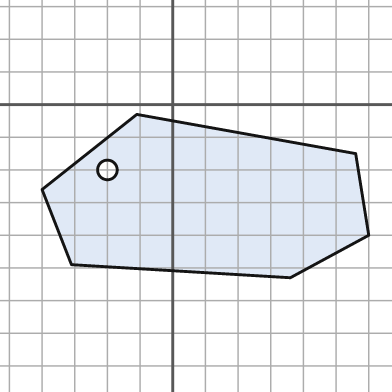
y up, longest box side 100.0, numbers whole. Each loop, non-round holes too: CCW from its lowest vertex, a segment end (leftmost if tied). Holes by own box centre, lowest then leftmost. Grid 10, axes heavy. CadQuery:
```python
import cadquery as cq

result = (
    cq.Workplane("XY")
    .moveTo(36.0, -53.0)
    .lineTo(60.0, -40.0)
    .lineTo(56.0, -15.0)
    .lineTo(-11.0, -3.0)
    .lineTo(-40.0, -26.0)
    .lineTo(-31.0, -49.0)
    .close()
    .moveTo(-20.0, -20.0)
    .circle(3.0)
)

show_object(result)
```